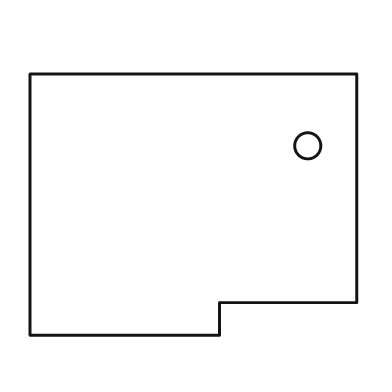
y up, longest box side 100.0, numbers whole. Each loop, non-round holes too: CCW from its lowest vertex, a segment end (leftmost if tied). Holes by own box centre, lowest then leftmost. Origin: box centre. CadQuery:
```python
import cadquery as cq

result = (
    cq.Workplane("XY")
    .moveTo(-50.0, -40.0)
    .lineTo(8.0, -40.0)
    .lineTo(8.0, -30.0)
    .lineTo(50.0, -30.0)
    .lineTo(50.0, 40.0)
    .lineTo(-50.0, 40.0)
    .close()
    .moveTo(35.0, 18.0)
    .circle(4.0)
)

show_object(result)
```